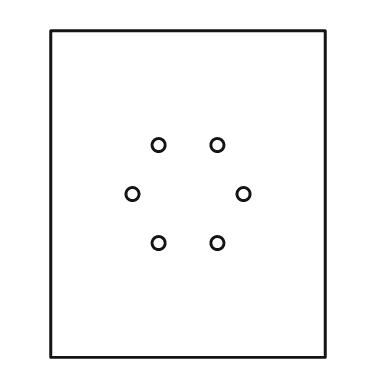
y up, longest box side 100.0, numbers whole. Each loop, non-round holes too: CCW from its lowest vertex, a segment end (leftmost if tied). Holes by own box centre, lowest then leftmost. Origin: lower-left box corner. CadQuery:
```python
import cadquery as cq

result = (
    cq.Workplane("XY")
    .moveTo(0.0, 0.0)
    .lineTo(84.0, 0.0)
    .lineTo(84.0, 100.0)
    .lineTo(0.0, 100.0)
    .close()
    .moveTo(33.0, 35.0)
    .circle(2.0)
    .moveTo(51.0, 35.0)
    .circle(2.0)
    .moveTo(25.0, 50.0)
    .circle(2.0)
    .moveTo(59.0, 50.0)
    .circle(2.0)
    .moveTo(33.0, 65.0)
    .circle(2.0)
    .moveTo(51.0, 65.0)
    .circle(2.0)
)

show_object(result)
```